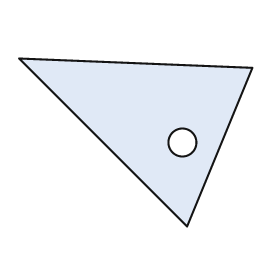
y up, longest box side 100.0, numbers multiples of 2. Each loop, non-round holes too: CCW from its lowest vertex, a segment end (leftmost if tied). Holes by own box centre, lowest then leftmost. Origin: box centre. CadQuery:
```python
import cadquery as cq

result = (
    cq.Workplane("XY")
    .moveTo(22.0, -36.0)
    .lineTo(50.0, 32.0)
    .lineTo(-50.0, 36.0)
    .close()
    .moveTo(20.0, 0.0)
    .circle(6.0)
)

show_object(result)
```